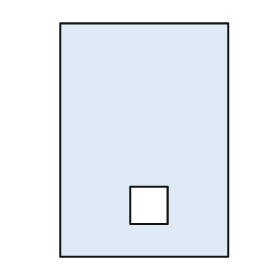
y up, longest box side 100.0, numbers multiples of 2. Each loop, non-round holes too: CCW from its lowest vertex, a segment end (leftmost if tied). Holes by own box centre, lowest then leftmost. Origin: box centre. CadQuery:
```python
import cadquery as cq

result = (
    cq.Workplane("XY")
    .moveTo(-36.0, -50.0)
    .lineTo(36.0, -50.0)
    .lineTo(36.0, 50.0)
    .lineTo(-36.0, 50.0)
    .close()
    .moveTo(-6.0, -36.0)
    .lineTo(10.0, -36.0)
    .lineTo(10.0, -20.0)
    .lineTo(-6.0, -20.0)
    .close()
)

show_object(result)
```